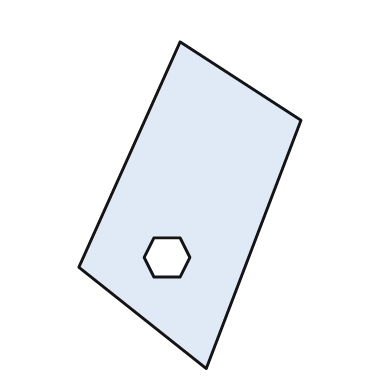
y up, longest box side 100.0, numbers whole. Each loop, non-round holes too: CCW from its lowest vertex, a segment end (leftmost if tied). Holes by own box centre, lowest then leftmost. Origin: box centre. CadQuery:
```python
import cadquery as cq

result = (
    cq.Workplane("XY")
    .moveTo(5.0, -50.0)
    .lineTo(34.0, 26.0)
    .lineTo(-3.0, 50.0)
    .lineTo(-34.0, -19.0)
    .close()
    .moveTo(-11.0, -22.0)
    .lineTo(-3.0, -22.0)
    .lineTo(0.0, -16.0)
    .lineTo(-3.0, -10.0)
    .lineTo(-11.0, -10.0)
    .lineTo(-14.0, -16.0)
    .close()
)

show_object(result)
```